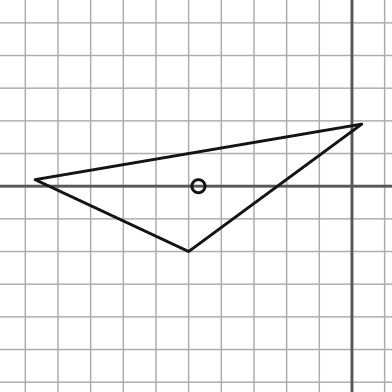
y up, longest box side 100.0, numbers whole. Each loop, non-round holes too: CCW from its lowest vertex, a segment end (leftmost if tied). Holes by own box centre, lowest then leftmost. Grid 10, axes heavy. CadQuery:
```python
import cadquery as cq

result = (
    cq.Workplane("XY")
    .moveTo(-50.0, -20.0)
    .lineTo(3.0, 19.0)
    .lineTo(-97.0, 2.0)
    .close()
    .moveTo(-47.0, 0.0)
    .circle(2.0)
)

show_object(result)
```